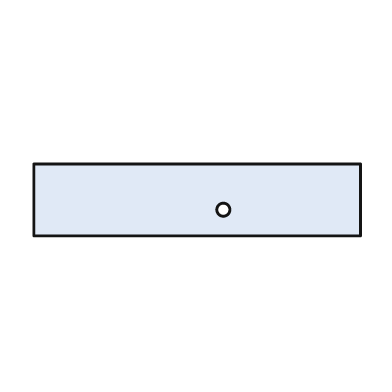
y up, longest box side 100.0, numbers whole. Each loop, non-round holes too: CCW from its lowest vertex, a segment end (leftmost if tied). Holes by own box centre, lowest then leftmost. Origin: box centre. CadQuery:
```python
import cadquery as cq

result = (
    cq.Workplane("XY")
    .moveTo(-50.0, -11.0)
    .lineTo(50.0, -11.0)
    .lineTo(50.0, 11.0)
    .lineTo(-50.0, 11.0)
    .close()
    .moveTo(8.0, -3.0)
    .circle(2.0)
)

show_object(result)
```